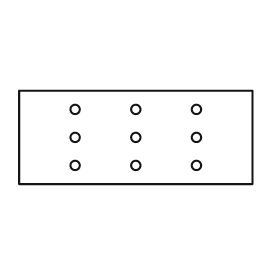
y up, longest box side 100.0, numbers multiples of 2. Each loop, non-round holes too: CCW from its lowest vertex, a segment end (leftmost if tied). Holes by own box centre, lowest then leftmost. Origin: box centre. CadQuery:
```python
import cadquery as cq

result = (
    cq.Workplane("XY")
    .moveTo(-50.0, -20.0)
    .lineTo(50.0, -20.0)
    .lineTo(50.0, 20.0)
    .lineTo(-50.0, 20.0)
    .close()
    .moveTo(-26.0, -12.0)
    .circle(2.0)
    .moveTo(0.0, -12.0)
    .circle(2.0)
    .moveTo(26.0, -12.0)
    .circle(2.0)
    .moveTo(-26.0, 0.0)
    .circle(2.0)
    .moveTo(0.0, 0.0)
    .circle(2.0)
    .moveTo(26.0, 0.0)
    .circle(2.0)
    .moveTo(-26.0, 12.0)
    .circle(2.0)
    .moveTo(0.0, 12.0)
    .circle(2.0)
    .moveTo(26.0, 12.0)
    .circle(2.0)
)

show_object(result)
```